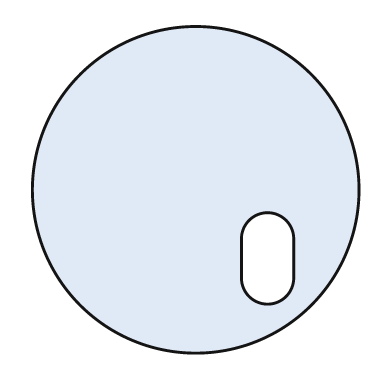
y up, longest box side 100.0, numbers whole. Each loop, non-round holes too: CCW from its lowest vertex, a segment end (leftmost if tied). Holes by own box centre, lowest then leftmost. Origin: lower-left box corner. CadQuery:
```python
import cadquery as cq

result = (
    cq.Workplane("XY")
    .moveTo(50.0, 50.0)
    .circle(50.0)
    .moveTo(64.0, 23.0)
    .threePointArc((72.0, 15.0), (80.0, 23.0))
    .lineTo(80.0, 35.0)
    .threePointArc((72.0, 43.0), (64.0, 35.0))
    .close()
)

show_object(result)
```